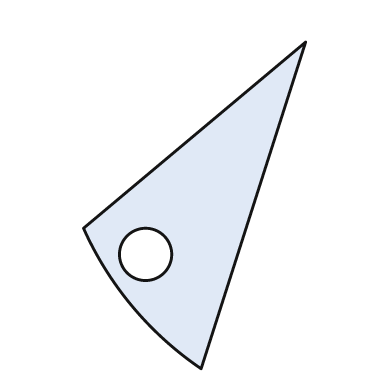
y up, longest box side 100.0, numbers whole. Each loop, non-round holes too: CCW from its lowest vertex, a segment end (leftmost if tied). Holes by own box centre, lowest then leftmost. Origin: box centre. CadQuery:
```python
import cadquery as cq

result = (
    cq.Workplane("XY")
    .moveTo(2.0, -50.0)
    .lineTo(34.0, 50.0)
    .lineTo(-34.0, -7.0)
    .threePointArc((-19.0, -31.0), (2.0, -50.0))
    .close()
    .moveTo(-15.0, -15.0)
    .circle(8.0)
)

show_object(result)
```